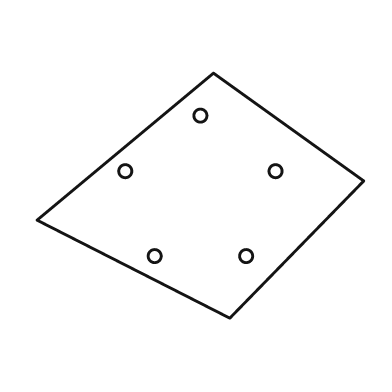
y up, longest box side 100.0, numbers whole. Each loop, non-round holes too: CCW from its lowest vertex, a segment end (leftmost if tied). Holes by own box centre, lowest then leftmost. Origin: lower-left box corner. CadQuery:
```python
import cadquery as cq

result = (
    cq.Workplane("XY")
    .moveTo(59.0, 0.0)
    .lineTo(100.0, 42.0)
    .lineTo(54.0, 75.0)
    .lineTo(0.0, 30.0)
    .close()
    .moveTo(36.0, 19.0)
    .circle(2.0)
    .moveTo(64.0, 19.0)
    .circle(2.0)
    .moveTo(27.0, 45.0)
    .circle(2.0)
    .moveTo(73.0, 45.0)
    .circle(2.0)
    .moveTo(50.0, 62.0)
    .circle(2.0)
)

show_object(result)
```